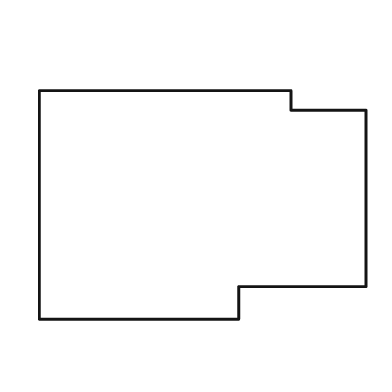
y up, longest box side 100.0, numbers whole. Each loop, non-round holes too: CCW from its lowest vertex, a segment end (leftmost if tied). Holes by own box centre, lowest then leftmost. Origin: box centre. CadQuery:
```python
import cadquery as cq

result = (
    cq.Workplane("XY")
    .moveTo(-50.0, -35.0)
    .lineTo(11.0, -35.0)
    .lineTo(11.0, -25.0)
    .lineTo(50.0, -25.0)
    .lineTo(50.0, 29.0)
    .lineTo(27.0, 29.0)
    .lineTo(27.0, 35.0)
    .lineTo(-50.0, 35.0)
    .close()
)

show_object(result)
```